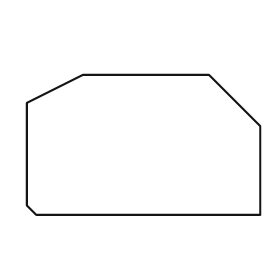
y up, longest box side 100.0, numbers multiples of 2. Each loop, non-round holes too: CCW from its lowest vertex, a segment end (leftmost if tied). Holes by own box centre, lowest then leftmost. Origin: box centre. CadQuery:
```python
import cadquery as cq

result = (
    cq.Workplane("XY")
    .moveTo(-46.0, -30.0)
    .lineTo(50.0, -30.0)
    .lineTo(50.0, 8.0)
    .lineTo(28.0, 30.0)
    .lineTo(-26.0, 30.0)
    .lineTo(-50.0, 18.0)
    .lineTo(-50.0, -26.0)
    .close()
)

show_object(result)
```